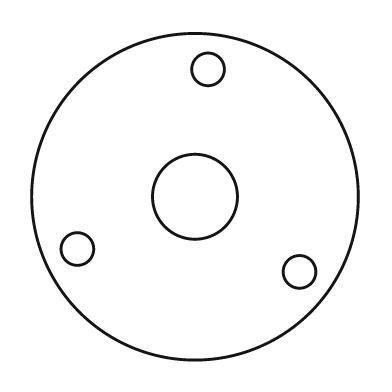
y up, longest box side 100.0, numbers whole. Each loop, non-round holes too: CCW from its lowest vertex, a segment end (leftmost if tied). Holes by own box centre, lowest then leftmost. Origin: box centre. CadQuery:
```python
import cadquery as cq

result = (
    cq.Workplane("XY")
    .moveTo(0.0, 0.0)
    .circle(50.0)
    .moveTo(32.0, -23.0)
    .circle(5.0)
    .moveTo(-36.0, -16.0)
    .circle(5.0)
    .moveTo(0.0, 0.0)
    .circle(13.0)
    .moveTo(4.0, 39.0)
    .circle(5.0)
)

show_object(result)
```